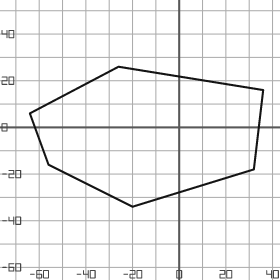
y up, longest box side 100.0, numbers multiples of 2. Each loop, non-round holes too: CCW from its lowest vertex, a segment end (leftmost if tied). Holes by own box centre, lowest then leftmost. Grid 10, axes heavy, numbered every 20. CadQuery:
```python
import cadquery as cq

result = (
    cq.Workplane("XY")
    .moveTo(-20.0, -34.0)
    .lineTo(32.0, -18.0)
    .lineTo(36.0, 16.0)
    .lineTo(-26.0, 26.0)
    .lineTo(-64.0, 6.0)
    .lineTo(-56.0, -16.0)
    .close()
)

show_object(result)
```